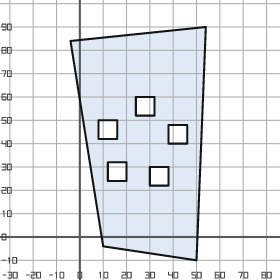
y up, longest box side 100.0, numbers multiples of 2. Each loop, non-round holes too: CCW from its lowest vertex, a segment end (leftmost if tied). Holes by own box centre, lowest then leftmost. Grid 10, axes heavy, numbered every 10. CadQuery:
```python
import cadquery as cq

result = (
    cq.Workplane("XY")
    .moveTo(50.0, -10.0)
    .lineTo(54.0, 90.0)
    .lineTo(-4.0, 84.0)
    .lineTo(10.0, -4.0)
    .close()
    .moveTo(30.0, 22.0)
    .lineTo(38.0, 22.0)
    .lineTo(38.0, 30.0)
    .lineTo(30.0, 30.0)
    .close()
    .moveTo(12.0, 24.0)
    .lineTo(20.0, 24.0)
    .lineTo(20.0, 32.0)
    .lineTo(12.0, 32.0)
    .close()
    .moveTo(38.0, 40.0)
    .lineTo(46.0, 40.0)
    .lineTo(46.0, 48.0)
    .lineTo(38.0, 48.0)
    .close()
    .moveTo(8.0, 42.0)
    .lineTo(16.0, 42.0)
    .lineTo(16.0, 50.0)
    .lineTo(8.0, 50.0)
    .close()
    .moveTo(24.0, 52.0)
    .lineTo(32.0, 52.0)
    .lineTo(32.0, 60.0)
    .lineTo(24.0, 60.0)
    .close()
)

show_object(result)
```